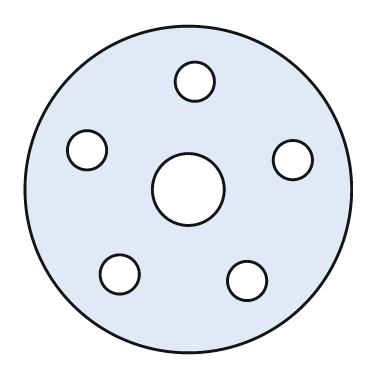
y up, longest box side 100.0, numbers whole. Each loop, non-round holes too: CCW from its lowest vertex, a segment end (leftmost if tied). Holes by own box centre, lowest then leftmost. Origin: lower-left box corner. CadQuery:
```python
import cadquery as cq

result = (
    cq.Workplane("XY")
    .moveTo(50.0, 50.0)
    .circle(50.0)
    .moveTo(68.0, 22.0)
    .circle(6.0)
    .moveTo(29.0, 24.0)
    .circle(6.0)
    .moveTo(50.0, 50.0)
    .circle(11.0)
    .moveTo(82.0, 59.0)
    .circle(6.0)
    .moveTo(19.0, 62.0)
    .circle(6.0)
    .moveTo(52.0, 83.0)
    .circle(6.0)
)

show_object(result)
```